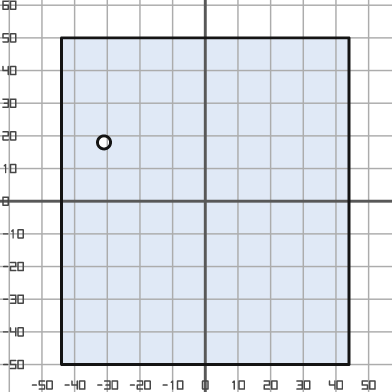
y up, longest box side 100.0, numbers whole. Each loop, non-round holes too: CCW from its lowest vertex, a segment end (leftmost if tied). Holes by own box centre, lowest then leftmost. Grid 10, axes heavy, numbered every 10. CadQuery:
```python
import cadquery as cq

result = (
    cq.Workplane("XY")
    .moveTo(-44.0, -50.0)
    .lineTo(44.0, -50.0)
    .lineTo(44.0, 50.0)
    .lineTo(-44.0, 50.0)
    .close()
    .moveTo(-31.0, 18.0)
    .circle(2.0)
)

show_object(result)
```